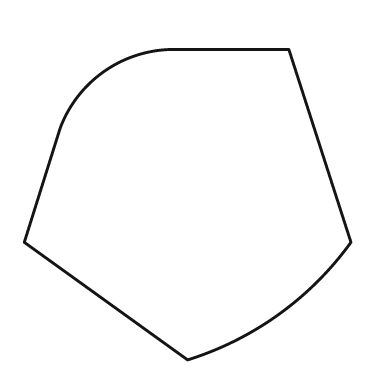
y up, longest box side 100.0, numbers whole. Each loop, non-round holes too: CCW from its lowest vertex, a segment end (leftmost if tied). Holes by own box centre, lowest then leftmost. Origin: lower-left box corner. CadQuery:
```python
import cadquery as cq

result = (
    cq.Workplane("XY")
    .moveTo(50.0, 0.0)
    .threePointArc((78.0, 14.0), (100.0, 36.0))
    .lineTo(81.0, 95.0)
    .lineTo(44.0, 95.0)
    .threePointArc((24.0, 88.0), (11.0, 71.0))
    .lineTo(0.0, 36.0)
    .close()
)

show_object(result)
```